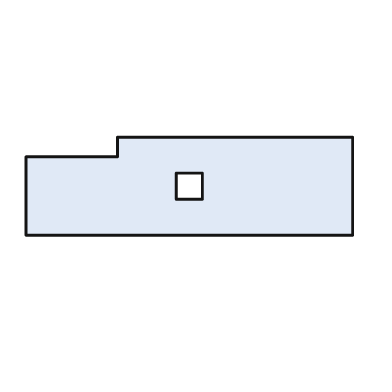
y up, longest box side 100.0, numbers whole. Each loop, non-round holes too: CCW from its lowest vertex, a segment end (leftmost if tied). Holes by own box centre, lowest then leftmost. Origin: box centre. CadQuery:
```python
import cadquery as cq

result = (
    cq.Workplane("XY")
    .moveTo(-50.0, -15.0)
    .lineTo(50.0, -15.0)
    .lineTo(50.0, 15.0)
    .lineTo(-22.0, 15.0)
    .lineTo(-22.0, 9.0)
    .lineTo(-50.0, 9.0)
    .close()
    .moveTo(-4.0, -4.0)
    .lineTo(4.0, -4.0)
    .lineTo(4.0, 4.0)
    .lineTo(-4.0, 4.0)
    .close()
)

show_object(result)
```